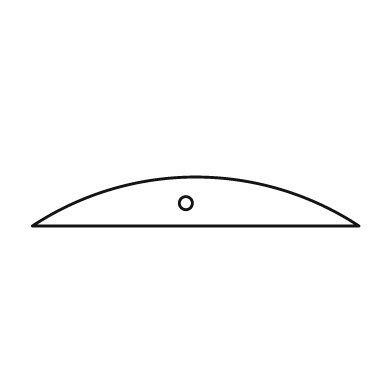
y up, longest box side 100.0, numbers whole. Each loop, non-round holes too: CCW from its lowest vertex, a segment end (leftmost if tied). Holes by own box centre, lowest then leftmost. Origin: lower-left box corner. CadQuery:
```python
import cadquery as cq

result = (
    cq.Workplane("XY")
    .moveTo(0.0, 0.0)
    .lineTo(100.0, 0.0)
    .threePointArc((50.0, 15.0), (0.0, 0.0))
    .close()
    .moveTo(47.0, 7.0)
    .circle(2.0)
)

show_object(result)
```